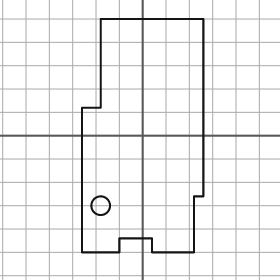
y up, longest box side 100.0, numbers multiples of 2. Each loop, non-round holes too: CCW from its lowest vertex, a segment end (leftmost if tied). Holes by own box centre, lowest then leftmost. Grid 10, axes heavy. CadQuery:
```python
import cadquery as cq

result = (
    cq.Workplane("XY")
    .moveTo(-26.0, -50.0)
    .lineTo(-10.0, -50.0)
    .lineTo(-10.0, -44.0)
    .lineTo(4.0, -44.0)
    .lineTo(4.0, -50.0)
    .lineTo(22.0, -50.0)
    .lineTo(22.0, -26.0)
    .lineTo(26.0, -26.0)
    .lineTo(26.0, 50.0)
    .lineTo(-18.0, 50.0)
    .lineTo(-18.0, 12.0)
    .lineTo(-26.0, 12.0)
    .close()
    .moveTo(-18.0, -30.0)
    .circle(4.0)
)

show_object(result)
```